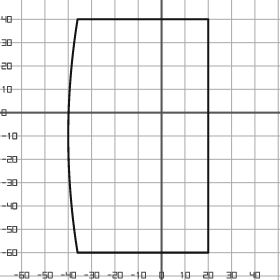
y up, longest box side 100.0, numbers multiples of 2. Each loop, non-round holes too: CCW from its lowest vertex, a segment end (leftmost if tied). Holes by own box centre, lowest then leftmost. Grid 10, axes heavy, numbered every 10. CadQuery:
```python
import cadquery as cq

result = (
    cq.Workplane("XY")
    .moveTo(-36.0, -60.0)
    .lineTo(20.0, -60.0)
    .lineTo(20.0, 40.0)
    .lineTo(-36.0, 40.0)
    .threePointArc((-40.0, -10.0), (-36.0, -60.0))
    .close()
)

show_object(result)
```